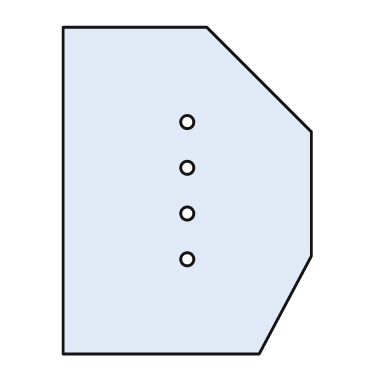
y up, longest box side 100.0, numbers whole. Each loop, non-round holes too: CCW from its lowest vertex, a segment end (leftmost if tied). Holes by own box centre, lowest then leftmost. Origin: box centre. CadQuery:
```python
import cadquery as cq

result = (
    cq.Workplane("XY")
    .moveTo(-38.0, -50.0)
    .lineTo(22.0, -50.0)
    .lineTo(38.0, -20.0)
    .lineTo(38.0, 18.0)
    .lineTo(6.0, 50.0)
    .lineTo(-38.0, 50.0)
    .close()
    .moveTo(0.0, -21.0)
    .circle(2.0)
    .moveTo(0.0, -7.0)
    .circle(2.0)
    .moveTo(0.0, 7.0)
    .circle(2.0)
    .moveTo(0.0, 21.0)
    .circle(2.0)
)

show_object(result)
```